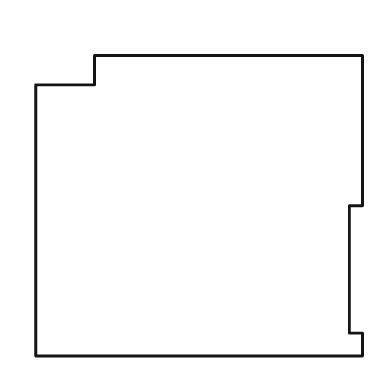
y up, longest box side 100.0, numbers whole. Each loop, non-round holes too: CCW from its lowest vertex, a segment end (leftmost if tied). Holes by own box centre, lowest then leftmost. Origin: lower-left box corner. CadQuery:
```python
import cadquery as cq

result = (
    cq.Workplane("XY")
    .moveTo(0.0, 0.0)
    .lineTo(100.0, 0.0)
    .lineTo(100.0, 7.0)
    .lineTo(96.0, 7.0)
    .lineTo(96.0, 46.0)
    .lineTo(100.0, 46.0)
    .lineTo(100.0, 92.0)
    .lineTo(18.0, 92.0)
    .lineTo(18.0, 83.0)
    .lineTo(0.0, 83.0)
    .close()
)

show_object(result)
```